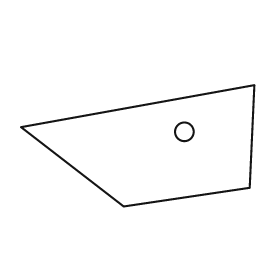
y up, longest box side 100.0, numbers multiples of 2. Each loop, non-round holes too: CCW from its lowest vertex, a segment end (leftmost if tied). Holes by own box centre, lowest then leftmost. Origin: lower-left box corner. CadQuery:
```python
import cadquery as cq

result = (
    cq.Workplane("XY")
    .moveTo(44.0, 0.0)
    .lineTo(98.0, 8.0)
    .lineTo(100.0, 52.0)
    .lineTo(0.0, 34.0)
    .close()
    .moveTo(70.0, 32.0)
    .circle(4.0)
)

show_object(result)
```